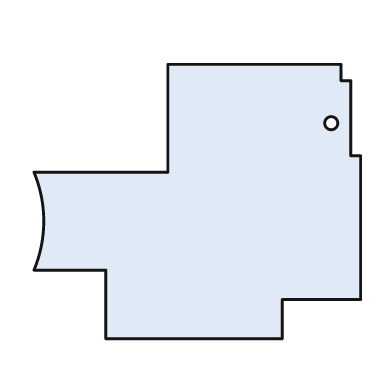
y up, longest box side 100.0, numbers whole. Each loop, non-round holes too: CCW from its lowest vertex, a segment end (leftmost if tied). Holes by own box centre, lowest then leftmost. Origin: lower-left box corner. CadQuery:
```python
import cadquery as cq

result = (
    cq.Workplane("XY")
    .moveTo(22.0, 0.0)
    .lineTo(76.0, 0.0)
    .lineTo(76.0, 12.0)
    .lineTo(100.0, 12.0)
    .lineTo(100.0, 56.0)
    .lineTo(97.0, 56.0)
    .lineTo(97.0, 79.0)
    .lineTo(94.0, 79.0)
    .lineTo(94.0, 84.0)
    .lineTo(41.0, 84.0)
    .lineTo(41.0, 51.0)
    .lineTo(0.0, 51.0)
    .threePointArc((3.0, 36.0), (0.0, 21.0))
    .lineTo(22.0, 21.0)
    .close()
    .moveTo(91.0, 66.0)
    .circle(2.0)
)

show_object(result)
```